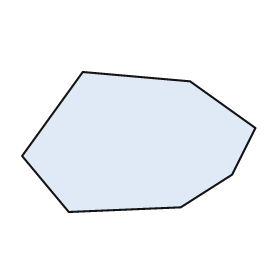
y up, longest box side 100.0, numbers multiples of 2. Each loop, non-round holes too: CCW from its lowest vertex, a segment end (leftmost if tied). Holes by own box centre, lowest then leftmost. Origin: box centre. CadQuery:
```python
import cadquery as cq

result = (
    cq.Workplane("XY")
    .moveTo(-30.0, -30.0)
    .lineTo(18.0, -28.0)
    .lineTo(40.0, -14.0)
    .lineTo(50.0, 6.0)
    .lineTo(22.0, 26.0)
    .lineTo(-24.0, 30.0)
    .lineTo(-50.0, -6.0)
    .close()
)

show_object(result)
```